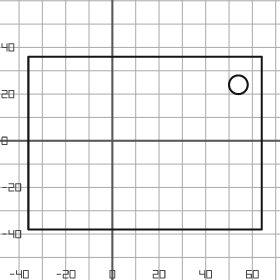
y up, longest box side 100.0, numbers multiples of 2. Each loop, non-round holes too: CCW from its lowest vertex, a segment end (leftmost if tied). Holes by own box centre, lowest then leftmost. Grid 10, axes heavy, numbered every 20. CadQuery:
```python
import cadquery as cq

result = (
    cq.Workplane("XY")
    .moveTo(-36.0, -38.0)
    .lineTo(64.0, -38.0)
    .lineTo(64.0, 36.0)
    .lineTo(-36.0, 36.0)
    .close()
    .moveTo(54.0, 24.0)
    .circle(4.0)
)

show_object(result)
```